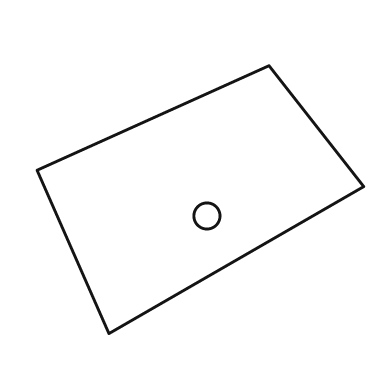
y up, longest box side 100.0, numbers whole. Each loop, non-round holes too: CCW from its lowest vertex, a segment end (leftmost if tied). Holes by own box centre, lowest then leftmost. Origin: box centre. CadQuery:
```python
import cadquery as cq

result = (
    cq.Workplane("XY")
    .moveTo(-28.0, -41.0)
    .lineTo(50.0, 4.0)
    .lineTo(21.0, 41.0)
    .lineTo(-50.0, 9.0)
    .close()
    .moveTo(2.0, -5.0)
    .circle(4.0)
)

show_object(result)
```